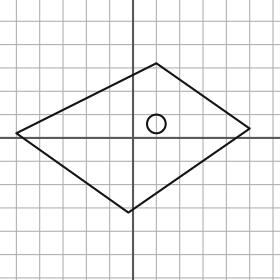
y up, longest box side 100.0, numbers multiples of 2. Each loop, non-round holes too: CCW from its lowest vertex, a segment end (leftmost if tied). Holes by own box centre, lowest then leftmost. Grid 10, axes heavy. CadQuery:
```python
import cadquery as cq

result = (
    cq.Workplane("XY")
    .moveTo(-2.0, -32.0)
    .lineTo(50.0, 4.0)
    .lineTo(10.0, 32.0)
    .lineTo(-50.0, 2.0)
    .close()
    .moveTo(10.0, 6.0)
    .circle(4.0)
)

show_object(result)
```